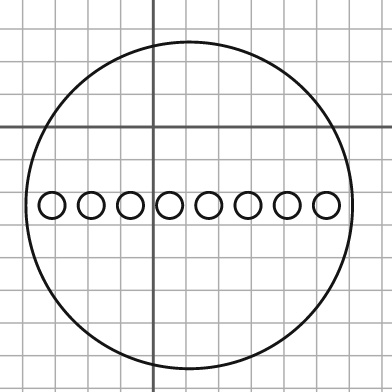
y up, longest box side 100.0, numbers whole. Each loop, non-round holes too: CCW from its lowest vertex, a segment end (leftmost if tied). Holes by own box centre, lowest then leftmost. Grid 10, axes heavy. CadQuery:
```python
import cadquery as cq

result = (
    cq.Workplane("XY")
    .moveTo(11.0, -24.0)
    .circle(50.0)
    .moveTo(-31.0, -24.0)
    .circle(4.0)
    .moveTo(-19.0, -24.0)
    .circle(4.0)
    .moveTo(-7.0, -24.0)
    .circle(4.0)
    .moveTo(5.0, -24.0)
    .circle(4.0)
    .moveTo(17.0, -24.0)
    .circle(4.0)
    .moveTo(29.0, -24.0)
    .circle(4.0)
    .moveTo(41.0, -24.0)
    .circle(4.0)
    .moveTo(53.0, -24.0)
    .circle(4.0)
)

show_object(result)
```